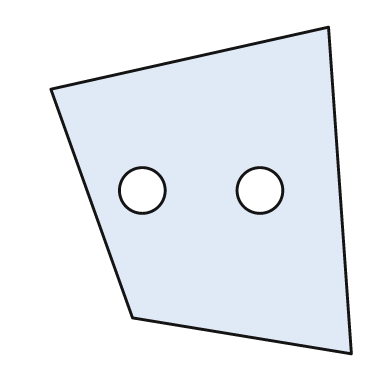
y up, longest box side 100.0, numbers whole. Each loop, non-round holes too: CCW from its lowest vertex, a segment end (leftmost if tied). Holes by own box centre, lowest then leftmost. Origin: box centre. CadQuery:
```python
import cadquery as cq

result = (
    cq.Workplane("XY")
    .moveTo(46.0, -50.0)
    .lineTo(39.0, 50.0)
    .lineTo(-46.0, 31.0)
    .lineTo(-21.0, -39.0)
    .close()
    .moveTo(-18.0, 0.0)
    .circle(7.0)
    .moveTo(18.0, 0.0)
    .circle(7.0)
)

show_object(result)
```